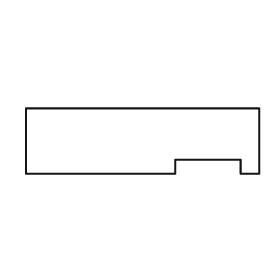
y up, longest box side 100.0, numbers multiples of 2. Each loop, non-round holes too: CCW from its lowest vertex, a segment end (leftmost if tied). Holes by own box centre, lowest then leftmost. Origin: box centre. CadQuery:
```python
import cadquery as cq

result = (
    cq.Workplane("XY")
    .moveTo(-50.0, -14.0)
    .lineTo(14.0, -14.0)
    .lineTo(14.0, -8.0)
    .lineTo(42.0, -8.0)
    .lineTo(42.0, -14.0)
    .lineTo(50.0, -14.0)
    .lineTo(50.0, 14.0)
    .lineTo(-50.0, 14.0)
    .close()
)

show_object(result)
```